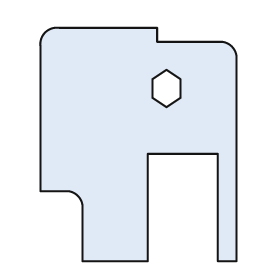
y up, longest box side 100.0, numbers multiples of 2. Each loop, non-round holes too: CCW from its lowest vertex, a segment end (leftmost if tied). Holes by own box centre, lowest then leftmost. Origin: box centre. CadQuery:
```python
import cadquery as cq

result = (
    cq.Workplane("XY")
    .moveTo(-24.0, -50.0)
    .lineTo(4.0, -50.0)
    .lineTo(4.0, -4.0)
    .lineTo(34.0, -4.0)
    .lineTo(34.0, -50.0)
    .lineTo(42.0, -50.0)
    .lineTo(42.0, 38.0)
    .threePointArc((40.0, 42.0), (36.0, 44.0))
    .lineTo(8.0, 44.0)
    .lineTo(8.0, 50.0)
    .lineTo(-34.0, 50.0)
    .threePointArc((-40.0, 48.0), (-42.0, 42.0))
    .lineTo(-42.0, -20.0)
    .lineTo(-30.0, -20.0)
    .threePointArc((-26.0, -22.0), (-24.0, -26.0))
    .close()
    .moveTo(12.0, 16.0)
    .lineTo(18.0, 20.0)
    .lineTo(18.0, 28.0)
    .lineTo(12.0, 32.0)
    .lineTo(6.0, 28.0)
    .lineTo(6.0, 20.0)
    .close()
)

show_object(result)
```